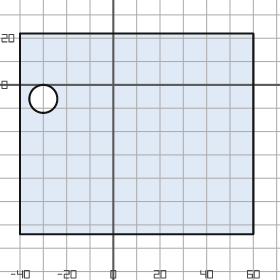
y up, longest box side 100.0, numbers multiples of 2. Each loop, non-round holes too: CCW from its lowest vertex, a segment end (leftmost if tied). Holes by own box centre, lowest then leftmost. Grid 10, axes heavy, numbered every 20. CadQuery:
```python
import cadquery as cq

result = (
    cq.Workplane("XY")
    .moveTo(-40.0, -64.0)
    .lineTo(60.0, -64.0)
    .lineTo(60.0, 22.0)
    .lineTo(-40.0, 22.0)
    .close()
    .moveTo(-30.0, -6.0)
    .circle(6.0)
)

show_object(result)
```